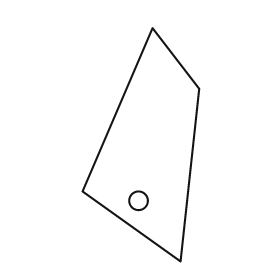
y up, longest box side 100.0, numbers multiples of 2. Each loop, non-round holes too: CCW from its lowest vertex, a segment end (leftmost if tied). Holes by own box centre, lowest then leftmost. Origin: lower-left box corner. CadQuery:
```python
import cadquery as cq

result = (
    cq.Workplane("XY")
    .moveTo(42.0, 0.0)
    .lineTo(50.0, 74.0)
    .lineTo(30.0, 100.0)
    .lineTo(0.0, 30.0)
    .close()
    .moveTo(24.0, 26.0)
    .circle(4.0)
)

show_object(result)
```